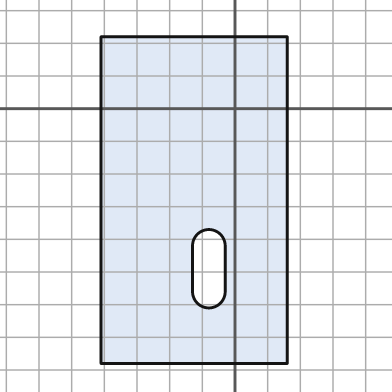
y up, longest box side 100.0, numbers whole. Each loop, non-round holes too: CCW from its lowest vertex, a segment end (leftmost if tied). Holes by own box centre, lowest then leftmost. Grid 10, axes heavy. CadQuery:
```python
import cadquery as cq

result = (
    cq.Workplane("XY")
    .moveTo(-41.0, -78.0)
    .lineTo(16.0, -78.0)
    .lineTo(16.0, 22.0)
    .lineTo(-41.0, 22.0)
    .close()
    .moveTo(-13.0, -56.0)
    .threePointArc((-8.0, -61.0), (-3.0, -56.0))
    .lineTo(-3.0, -42.0)
    .threePointArc((-8.0, -37.0), (-13.0, -42.0))
    .close()
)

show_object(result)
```